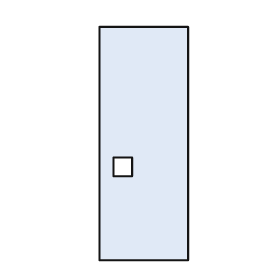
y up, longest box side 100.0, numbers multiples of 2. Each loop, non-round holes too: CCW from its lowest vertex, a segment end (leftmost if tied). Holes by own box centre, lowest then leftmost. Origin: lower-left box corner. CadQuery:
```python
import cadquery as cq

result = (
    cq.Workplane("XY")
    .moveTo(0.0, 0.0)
    .lineTo(38.0, 0.0)
    .lineTo(38.0, 100.0)
    .lineTo(0.0, 100.0)
    .close()
    .moveTo(6.0, 36.0)
    .lineTo(14.0, 36.0)
    .lineTo(14.0, 44.0)
    .lineTo(6.0, 44.0)
    .close()
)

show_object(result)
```